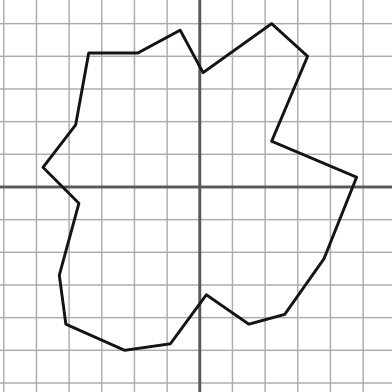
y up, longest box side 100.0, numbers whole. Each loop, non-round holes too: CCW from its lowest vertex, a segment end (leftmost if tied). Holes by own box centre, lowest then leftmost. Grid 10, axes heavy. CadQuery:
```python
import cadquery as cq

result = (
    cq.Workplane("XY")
    .moveTo(-23.0, -50.0)
    .lineTo(-9.0, -48.0)
    .lineTo(2.0, -33.0)
    .lineTo(15.0, -42.0)
    .lineTo(26.0, -39.0)
    .lineTo(38.0, -22.0)
    .lineTo(48.0, 3.0)
    .lineTo(22.0, 14.0)
    .lineTo(33.0, 40.0)
    .lineTo(22.0, 50.0)
    .lineTo(1.0, 35.0)
    .lineTo(-6.0, 48.0)
    .lineTo(-19.0, 41.0)
    .lineTo(-34.0, 41.0)
    .lineTo(-38.0, 19.0)
    .lineTo(-48.0, 6.0)
    .lineTo(-37.0, -5.0)
    .lineTo(-43.0, -27.0)
    .lineTo(-41.0, -42.0)
    .close()
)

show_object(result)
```